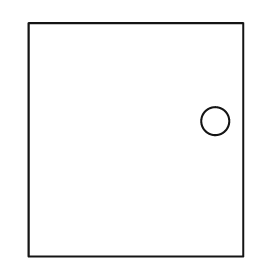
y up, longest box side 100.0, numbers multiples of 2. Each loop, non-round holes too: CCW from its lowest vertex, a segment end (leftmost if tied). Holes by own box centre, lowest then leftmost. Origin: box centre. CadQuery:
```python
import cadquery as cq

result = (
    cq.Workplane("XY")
    .moveTo(-46.0, -50.0)
    .lineTo(46.0, -50.0)
    .lineTo(46.0, 50.0)
    .lineTo(-46.0, 50.0)
    .close()
    .moveTo(34.0, 8.0)
    .circle(6.0)
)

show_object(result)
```